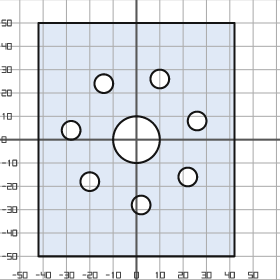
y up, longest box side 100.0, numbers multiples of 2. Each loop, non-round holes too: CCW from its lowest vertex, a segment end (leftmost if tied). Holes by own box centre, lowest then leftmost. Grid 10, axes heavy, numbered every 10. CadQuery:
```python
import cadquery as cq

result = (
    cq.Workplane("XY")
    .moveTo(-42.0, -50.0)
    .lineTo(42.0, -50.0)
    .lineTo(42.0, 50.0)
    .lineTo(-42.0, 50.0)
    .close()
    .moveTo(2.0, -28.0)
    .circle(4.0)
    .moveTo(-20.0, -18.0)
    .circle(4.0)
    .moveTo(22.0, -16.0)
    .circle(4.0)
    .moveTo(0.0, 0.0)
    .circle(10.0)
    .moveTo(-28.0, 4.0)
    .circle(4.0)
    .moveTo(26.0, 8.0)
    .circle(4.0)
    .moveTo(-14.0, 24.0)
    .circle(4.0)
    .moveTo(10.0, 26.0)
    .circle(4.0)
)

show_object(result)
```